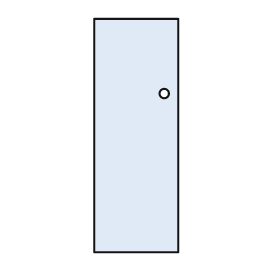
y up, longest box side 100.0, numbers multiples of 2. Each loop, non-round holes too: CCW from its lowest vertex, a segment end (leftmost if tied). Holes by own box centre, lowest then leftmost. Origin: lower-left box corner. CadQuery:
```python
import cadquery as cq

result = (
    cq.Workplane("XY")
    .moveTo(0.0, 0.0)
    .lineTo(36.0, 0.0)
    .lineTo(36.0, 100.0)
    .lineTo(0.0, 100.0)
    .close()
    .moveTo(30.0, 68.0)
    .circle(2.0)
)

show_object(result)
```